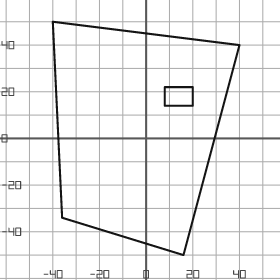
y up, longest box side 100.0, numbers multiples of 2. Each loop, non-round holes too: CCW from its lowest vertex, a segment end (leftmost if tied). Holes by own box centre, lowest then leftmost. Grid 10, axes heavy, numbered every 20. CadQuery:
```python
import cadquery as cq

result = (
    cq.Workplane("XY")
    .moveTo(16.0, -50.0)
    .lineTo(40.0, 40.0)
    .lineTo(-40.0, 50.0)
    .lineTo(-36.0, -34.0)
    .close()
    .moveTo(8.0, 14.0)
    .lineTo(20.0, 14.0)
    .lineTo(20.0, 22.0)
    .lineTo(8.0, 22.0)
    .close()
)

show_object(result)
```